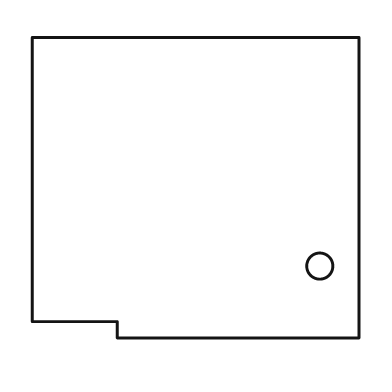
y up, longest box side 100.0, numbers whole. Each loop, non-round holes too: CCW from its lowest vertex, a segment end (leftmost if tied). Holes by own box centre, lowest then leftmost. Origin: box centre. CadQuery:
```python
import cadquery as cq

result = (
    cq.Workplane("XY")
    .moveTo(-24.0, -46.0)
    .lineTo(50.0, -46.0)
    .lineTo(50.0, 46.0)
    .lineTo(-50.0, 46.0)
    .lineTo(-50.0, -41.0)
    .lineTo(-24.0, -41.0)
    .close()
    .moveTo(38.0, -24.0)
    .circle(4.0)
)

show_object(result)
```